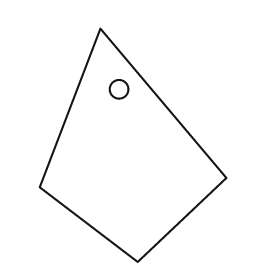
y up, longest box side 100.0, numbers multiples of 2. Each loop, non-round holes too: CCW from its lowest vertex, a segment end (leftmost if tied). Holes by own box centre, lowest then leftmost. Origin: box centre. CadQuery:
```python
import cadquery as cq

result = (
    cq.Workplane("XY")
    .moveTo(2.0, -50.0)
    .lineTo(40.0, -14.0)
    .lineTo(-14.0, 50.0)
    .lineTo(-40.0, -18.0)
    .close()
    .moveTo(-6.0, 24.0)
    .circle(4.0)
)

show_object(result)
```